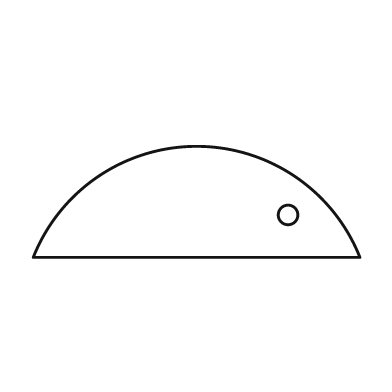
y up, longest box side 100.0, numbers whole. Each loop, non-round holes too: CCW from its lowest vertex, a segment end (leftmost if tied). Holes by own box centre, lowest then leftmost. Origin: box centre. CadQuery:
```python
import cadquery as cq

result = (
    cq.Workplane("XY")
    .moveTo(-50.0, -17.0)
    .lineTo(50.0, -17.0)
    .threePointArc((0.0, 17.0), (-50.0, -17.0))
    .close()
    .moveTo(28.0, -4.0)
    .circle(3.0)
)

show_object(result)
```